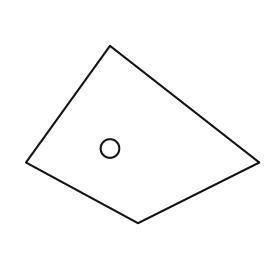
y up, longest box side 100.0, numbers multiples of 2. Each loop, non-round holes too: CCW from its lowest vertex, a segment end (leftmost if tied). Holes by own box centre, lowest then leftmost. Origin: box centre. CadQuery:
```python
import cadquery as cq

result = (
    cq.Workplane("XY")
    .moveTo(-2.0, -38.0)
    .lineTo(50.0, -12.0)
    .lineTo(-14.0, 38.0)
    .lineTo(-50.0, -12.0)
    .close()
    .moveTo(-14.0, -6.0)
    .circle(4.0)
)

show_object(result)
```